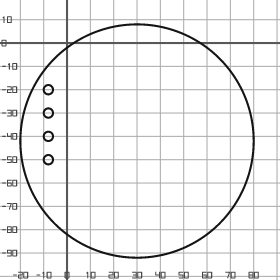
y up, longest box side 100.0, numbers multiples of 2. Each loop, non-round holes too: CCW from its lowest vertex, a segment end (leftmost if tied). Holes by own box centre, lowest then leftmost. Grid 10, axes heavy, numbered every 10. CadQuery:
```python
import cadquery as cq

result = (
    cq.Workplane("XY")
    .moveTo(30.0, -42.0)
    .circle(50.0)
    .moveTo(-8.0, -50.0)
    .circle(2.0)
    .moveTo(-8.0, -40.0)
    .circle(2.0)
    .moveTo(-8.0, -30.0)
    .circle(2.0)
    .moveTo(-8.0, -20.0)
    .circle(2.0)
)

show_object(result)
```